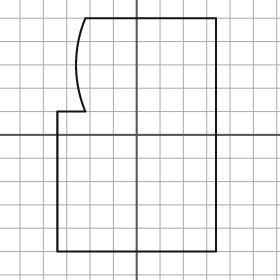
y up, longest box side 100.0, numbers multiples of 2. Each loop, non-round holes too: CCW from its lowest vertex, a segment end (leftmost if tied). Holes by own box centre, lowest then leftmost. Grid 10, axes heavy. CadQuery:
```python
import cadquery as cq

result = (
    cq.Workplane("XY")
    .moveTo(-34.0, -50.0)
    .lineTo(34.0, -50.0)
    .lineTo(34.0, 50.0)
    .lineTo(-22.0, 50.0)
    .threePointArc((-26.0, 30.0), (-22.0, 10.0))
    .lineTo(-34.0, 10.0)
    .close()
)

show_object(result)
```